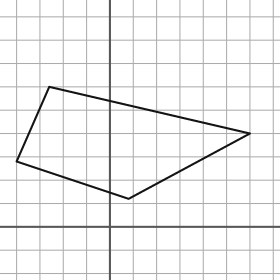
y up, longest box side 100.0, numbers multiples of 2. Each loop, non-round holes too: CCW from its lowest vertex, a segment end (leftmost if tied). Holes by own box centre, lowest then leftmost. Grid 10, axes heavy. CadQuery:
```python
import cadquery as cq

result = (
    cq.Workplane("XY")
    .moveTo(8.0, 12.0)
    .lineTo(60.0, 40.0)
    .lineTo(-26.0, 60.0)
    .lineTo(-40.0, 28.0)
    .close()
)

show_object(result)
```